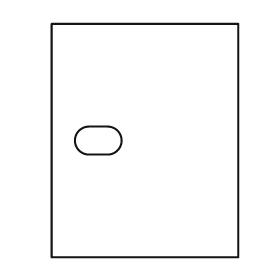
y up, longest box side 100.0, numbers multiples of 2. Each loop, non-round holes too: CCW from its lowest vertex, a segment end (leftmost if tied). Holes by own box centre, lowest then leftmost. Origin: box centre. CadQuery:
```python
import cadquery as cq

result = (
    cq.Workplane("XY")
    .moveTo(-40.0, -50.0)
    .lineTo(40.0, -50.0)
    .lineTo(40.0, 50.0)
    .lineTo(-40.0, 50.0)
    .close()
    .moveTo(-24.0, -6.0)
    .lineTo(-16.0, -6.0)
    .threePointArc((-10.0, 0.0), (-16.0, 6.0))
    .lineTo(-24.0, 6.0)
    .threePointArc((-30.0, 0.0), (-24.0, -6.0))
    .close()
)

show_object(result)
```